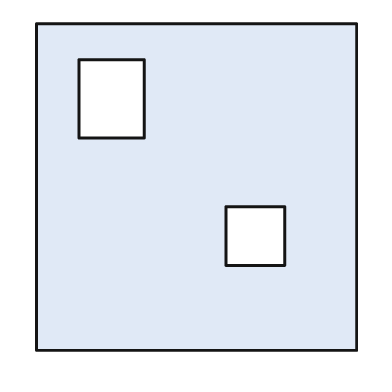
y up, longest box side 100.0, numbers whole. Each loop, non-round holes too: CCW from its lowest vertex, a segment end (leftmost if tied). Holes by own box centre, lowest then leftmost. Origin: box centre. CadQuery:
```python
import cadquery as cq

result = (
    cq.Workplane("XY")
    .moveTo(-49.0, -50.0)
    .lineTo(49.0, -50.0)
    .lineTo(49.0, 50.0)
    .lineTo(-49.0, 50.0)
    .close()
    .moveTo(9.0, -24.0)
    .lineTo(27.0, -24.0)
    .lineTo(27.0, -6.0)
    .lineTo(9.0, -6.0)
    .close()
    .moveTo(-36.0, 15.0)
    .lineTo(-16.0, 15.0)
    .lineTo(-16.0, 39.0)
    .lineTo(-36.0, 39.0)
    .close()
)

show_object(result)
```